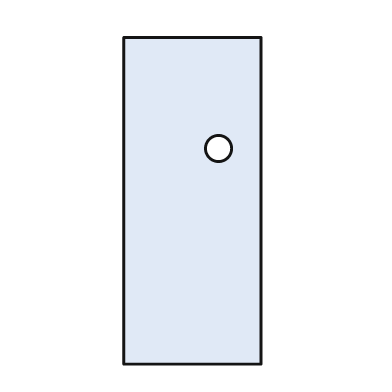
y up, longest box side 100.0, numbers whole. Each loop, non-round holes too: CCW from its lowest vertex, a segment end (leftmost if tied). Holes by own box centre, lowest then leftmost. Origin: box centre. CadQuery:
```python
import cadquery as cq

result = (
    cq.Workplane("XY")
    .moveTo(-21.0, -50.0)
    .lineTo(21.0, -50.0)
    .lineTo(21.0, 50.0)
    .lineTo(-21.0, 50.0)
    .close()
    .moveTo(8.0, 16.0)
    .circle(4.0)
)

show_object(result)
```